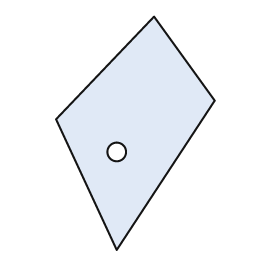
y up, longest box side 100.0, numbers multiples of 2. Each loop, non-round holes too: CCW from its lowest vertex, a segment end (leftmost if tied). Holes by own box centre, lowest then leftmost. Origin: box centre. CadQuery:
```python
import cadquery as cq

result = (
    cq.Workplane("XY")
    .moveTo(-8.0, -50.0)
    .lineTo(34.0, 14.0)
    .lineTo(8.0, 50.0)
    .lineTo(-34.0, 6.0)
    .close()
    .moveTo(-8.0, -8.0)
    .circle(4.0)
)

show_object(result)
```